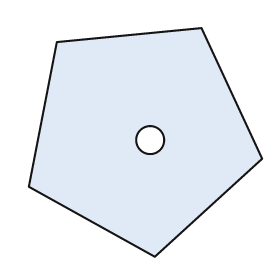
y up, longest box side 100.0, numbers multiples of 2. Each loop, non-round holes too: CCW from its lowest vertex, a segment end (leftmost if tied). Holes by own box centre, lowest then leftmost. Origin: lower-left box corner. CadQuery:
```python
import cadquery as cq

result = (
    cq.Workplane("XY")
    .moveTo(54.0, 0.0)
    .lineTo(100.0, 42.0)
    .lineTo(74.0, 98.0)
    .lineTo(12.0, 92.0)
    .lineTo(0.0, 30.0)
    .close()
    .moveTo(52.0, 50.0)
    .circle(6.0)
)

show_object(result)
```